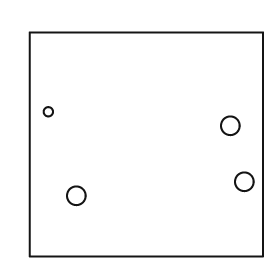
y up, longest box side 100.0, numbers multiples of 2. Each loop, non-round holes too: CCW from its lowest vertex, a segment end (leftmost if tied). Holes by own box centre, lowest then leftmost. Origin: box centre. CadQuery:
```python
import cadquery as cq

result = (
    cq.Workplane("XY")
    .moveTo(-50.0, -48.0)
    .lineTo(50.0, -48.0)
    .lineTo(50.0, 48.0)
    .lineTo(-50.0, 48.0)
    .close()
    .moveTo(-30.0, -22.0)
    .circle(4.0)
    .moveTo(42.0, -16.0)
    .circle(4.0)
    .moveTo(36.0, 8.0)
    .circle(4.0)
    .moveTo(-42.0, 14.0)
    .circle(2.0)
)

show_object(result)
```